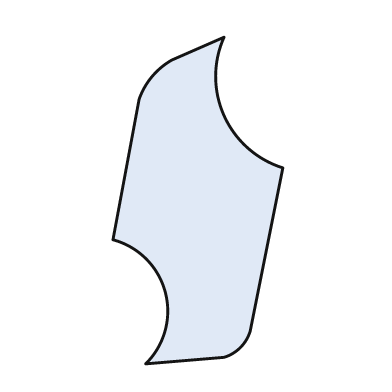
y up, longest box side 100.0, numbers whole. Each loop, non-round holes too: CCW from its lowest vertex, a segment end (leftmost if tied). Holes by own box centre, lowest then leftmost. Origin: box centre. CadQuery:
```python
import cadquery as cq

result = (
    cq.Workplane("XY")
    .moveTo(-16.0, -50.0)
    .lineTo(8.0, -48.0)
    .threePointArc((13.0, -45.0), (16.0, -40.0))
    .lineTo(26.0, 10.0)
    .threePointArc((8.0, 26.0), (8.0, 50.0))
    .lineTo(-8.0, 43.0)
    .threePointArc((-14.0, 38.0), (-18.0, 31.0))
    .lineTo(-26.0, -12.0)
    .threePointArc((-10.0, -28.0), (-16.0, -50.0))
    .close()
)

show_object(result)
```